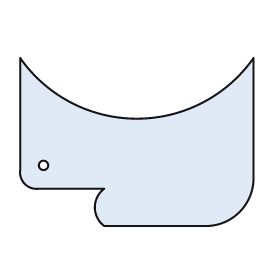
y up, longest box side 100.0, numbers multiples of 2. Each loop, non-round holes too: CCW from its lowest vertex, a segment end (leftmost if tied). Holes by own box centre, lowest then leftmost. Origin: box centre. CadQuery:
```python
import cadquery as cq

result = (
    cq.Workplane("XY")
    .moveTo(-14.0, -36.0)
    .lineTo(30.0, -36.0)
    .threePointArc((44.0, -30.0), (50.0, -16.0))
    .lineTo(50.0, 36.0)
    .threePointArc((0.0, 10.0), (-50.0, 36.0))
    .lineTo(-50.0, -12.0)
    .threePointArc((-48.0, -18.0), (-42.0, -20.0))
    .lineTo(-14.0, -20.0)
    .threePointArc((-18.0, -28.0), (-14.0, -36.0))
    .close()
    .moveTo(-40.0, -10.0)
    .circle(2.0)
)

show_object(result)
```